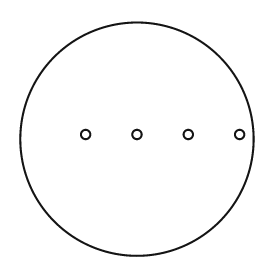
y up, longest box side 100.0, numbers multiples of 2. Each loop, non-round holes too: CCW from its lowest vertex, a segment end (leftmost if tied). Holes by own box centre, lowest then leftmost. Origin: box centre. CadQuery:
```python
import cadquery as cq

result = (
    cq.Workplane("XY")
    .moveTo(0.0, 0.0)
    .circle(50.0)
    .moveTo(-22.0, 2.0)
    .circle(2.0)
    .moveTo(0.0, 2.0)
    .circle(2.0)
    .moveTo(22.0, 2.0)
    .circle(2.0)
    .moveTo(44.0, 2.0)
    .circle(2.0)
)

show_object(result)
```